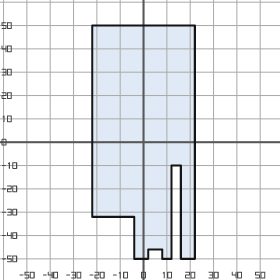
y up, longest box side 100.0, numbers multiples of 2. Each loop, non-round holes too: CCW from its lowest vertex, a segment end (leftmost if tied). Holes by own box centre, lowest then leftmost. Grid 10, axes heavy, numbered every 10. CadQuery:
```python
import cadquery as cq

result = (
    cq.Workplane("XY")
    .moveTo(-4.0, -50.0)
    .lineTo(2.0, -50.0)
    .lineTo(2.0, -46.0)
    .lineTo(8.0, -46.0)
    .lineTo(8.0, -50.0)
    .lineTo(12.0, -50.0)
    .lineTo(12.0, -10.0)
    .lineTo(16.0, -10.0)
    .lineTo(16.0, -50.0)
    .lineTo(22.0, -50.0)
    .lineTo(22.0, 50.0)
    .lineTo(-22.0, 50.0)
    .lineTo(-22.0, -32.0)
    .lineTo(-4.0, -32.0)
    .close()
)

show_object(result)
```